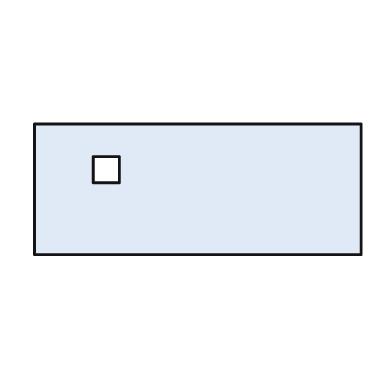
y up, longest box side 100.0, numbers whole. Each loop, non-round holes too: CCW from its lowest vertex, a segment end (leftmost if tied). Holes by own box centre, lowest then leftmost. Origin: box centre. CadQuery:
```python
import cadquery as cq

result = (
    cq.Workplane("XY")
    .moveTo(-50.0, -20.0)
    .lineTo(50.0, -20.0)
    .lineTo(50.0, 20.0)
    .lineTo(-50.0, 20.0)
    .close()
    .moveTo(-32.0, 2.0)
    .lineTo(-24.0, 2.0)
    .lineTo(-24.0, 10.0)
    .lineTo(-32.0, 10.0)
    .close()
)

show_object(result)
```